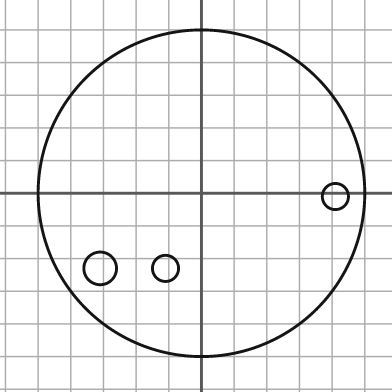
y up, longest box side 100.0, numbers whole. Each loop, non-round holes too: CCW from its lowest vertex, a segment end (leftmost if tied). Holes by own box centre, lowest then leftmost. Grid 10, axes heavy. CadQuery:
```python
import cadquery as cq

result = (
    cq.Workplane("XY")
    .moveTo(0.0, 0.0)
    .circle(50.0)
    .moveTo(-31.0, -23.0)
    .circle(5.0)
    .moveTo(-11.0, -23.0)
    .circle(4.0)
    .moveTo(41.0, -1.0)
    .circle(4.0)
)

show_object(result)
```